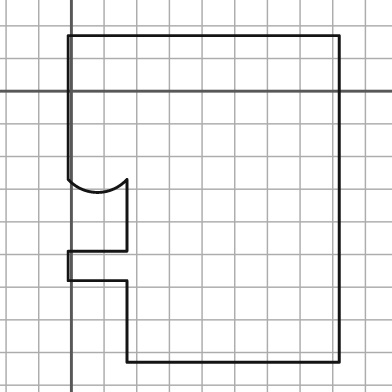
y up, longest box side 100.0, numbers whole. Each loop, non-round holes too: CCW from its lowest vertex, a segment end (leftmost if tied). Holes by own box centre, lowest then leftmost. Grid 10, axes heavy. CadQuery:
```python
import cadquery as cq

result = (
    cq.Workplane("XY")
    .moveTo(17.0, -83.0)
    .lineTo(82.0, -83.0)
    .lineTo(82.0, 17.0)
    .lineTo(-1.0, 17.0)
    .lineTo(-1.0, -27.0)
    .threePointArc((8.0, -31.0), (17.0, -27.0))
    .lineTo(17.0, -49.0)
    .lineTo(-1.0, -49.0)
    .lineTo(-1.0, -58.0)
    .lineTo(17.0, -58.0)
    .close()
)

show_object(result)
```